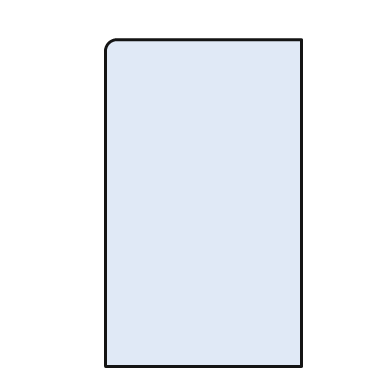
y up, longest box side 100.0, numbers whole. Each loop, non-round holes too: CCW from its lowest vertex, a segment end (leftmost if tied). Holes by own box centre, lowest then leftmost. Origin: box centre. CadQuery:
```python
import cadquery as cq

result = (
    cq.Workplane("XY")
    .moveTo(-30.0, -50.0)
    .lineTo(30.0, -50.0)
    .lineTo(30.0, 50.0)
    .lineTo(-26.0, 50.0)
    .threePointArc((-29.0, 49.0), (-30.0, 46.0))
    .close()
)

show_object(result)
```